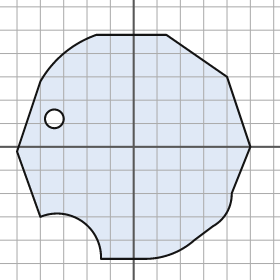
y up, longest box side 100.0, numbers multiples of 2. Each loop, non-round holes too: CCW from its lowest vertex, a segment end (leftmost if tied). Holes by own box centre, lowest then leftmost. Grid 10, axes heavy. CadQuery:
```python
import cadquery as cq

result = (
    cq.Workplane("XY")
    .moveTo(-14.0, -48.0)
    .lineTo(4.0, -48.0)
    .threePointArc((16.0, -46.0), (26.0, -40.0))
    .lineTo(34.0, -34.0)
    .threePointArc((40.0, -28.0), (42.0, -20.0))
    .lineTo(50.0, 0.0)
    .lineTo(40.0, 30.0)
    .lineTo(14.0, 48.0)
    .lineTo(-16.0, 48.0)
    .threePointArc((-30.0, 40.0), (-40.0, 28.0))
    .lineTo(-50.0, -2.0)
    .lineTo(-40.0, -30.0)
    .threePointArc((-22.0, -32.0), (-14.0, -48.0))
    .close()
    .moveTo(-34.0, 12.0)
    .circle(4.0)
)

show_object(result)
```